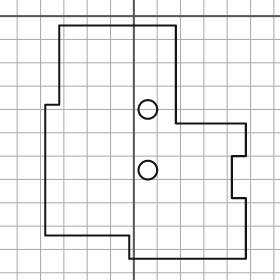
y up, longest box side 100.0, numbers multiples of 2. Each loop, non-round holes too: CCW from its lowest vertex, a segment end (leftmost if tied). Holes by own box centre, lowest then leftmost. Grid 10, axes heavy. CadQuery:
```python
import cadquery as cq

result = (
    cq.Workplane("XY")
    .moveTo(-2.0, -104.0)
    .lineTo(48.0, -104.0)
    .lineTo(48.0, -78.0)
    .lineTo(42.0, -78.0)
    .lineTo(42.0, -60.0)
    .lineTo(48.0, -60.0)
    .lineTo(48.0, -46.0)
    .lineTo(18.0, -46.0)
    .lineTo(18.0, -4.0)
    .lineTo(-32.0, -4.0)
    .lineTo(-32.0, -38.0)
    .lineTo(-38.0, -38.0)
    .lineTo(-38.0, -94.0)
    .lineTo(-2.0, -94.0)
    .close()
    .moveTo(6.0, -66.0)
    .circle(4.0)
    .moveTo(6.0, -40.0)
    .circle(4.0)
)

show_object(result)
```